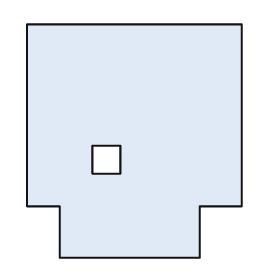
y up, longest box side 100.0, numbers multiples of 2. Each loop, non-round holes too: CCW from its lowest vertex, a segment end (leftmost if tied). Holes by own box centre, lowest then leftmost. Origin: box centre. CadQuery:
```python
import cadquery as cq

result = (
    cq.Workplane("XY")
    .moveTo(-32.0, -50.0)
    .lineTo(28.0, -50.0)
    .lineTo(28.0, -28.0)
    .lineTo(46.0, -28.0)
    .lineTo(46.0, 50.0)
    .lineTo(-46.0, 50.0)
    .lineTo(-46.0, -28.0)
    .lineTo(-32.0, -28.0)
    .close()
    .moveTo(-18.0, -14.0)
    .lineTo(-6.0, -14.0)
    .lineTo(-6.0, -2.0)
    .lineTo(-18.0, -2.0)
    .close()
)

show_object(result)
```